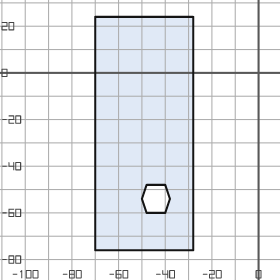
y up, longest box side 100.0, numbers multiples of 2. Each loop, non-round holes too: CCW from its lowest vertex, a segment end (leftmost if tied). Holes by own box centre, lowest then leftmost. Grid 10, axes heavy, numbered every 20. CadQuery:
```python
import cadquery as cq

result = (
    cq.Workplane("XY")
    .moveTo(-70.0, -76.0)
    .lineTo(-28.0, -76.0)
    .lineTo(-28.0, 24.0)
    .lineTo(-70.0, 24.0)
    .close()
    .moveTo(-48.0, -60.0)
    .lineTo(-40.0, -60.0)
    .lineTo(-38.0, -54.0)
    .lineTo(-40.0, -48.0)
    .lineTo(-48.0, -48.0)
    .lineTo(-50.0, -54.0)
    .close()
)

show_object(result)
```